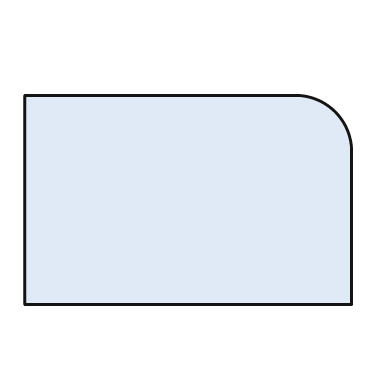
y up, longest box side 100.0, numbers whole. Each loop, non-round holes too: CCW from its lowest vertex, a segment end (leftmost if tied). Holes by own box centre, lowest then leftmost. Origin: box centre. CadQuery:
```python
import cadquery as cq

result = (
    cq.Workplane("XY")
    .moveTo(-50.0, -32.0)
    .lineTo(50.0, -32.0)
    .lineTo(50.0, 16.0)
    .threePointArc((45.0, 27.0), (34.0, 32.0))
    .lineTo(-50.0, 32.0)
    .close()
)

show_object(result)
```